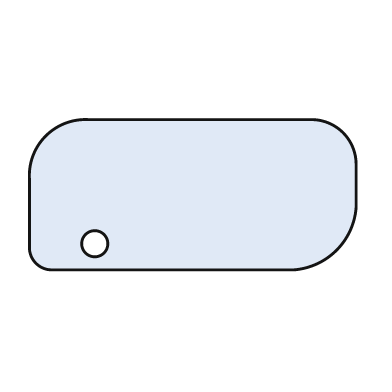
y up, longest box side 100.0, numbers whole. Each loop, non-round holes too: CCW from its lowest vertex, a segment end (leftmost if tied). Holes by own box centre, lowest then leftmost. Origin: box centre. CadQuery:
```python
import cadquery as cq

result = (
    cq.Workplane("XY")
    .moveTo(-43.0, -23.0)
    .lineTo(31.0, -23.0)
    .threePointArc((44.0, -17.0), (50.0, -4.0))
    .lineTo(50.0, 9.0)
    .threePointArc((46.0, 19.0), (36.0, 23.0))
    .lineTo(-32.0, 23.0)
    .threePointArc((-45.0, 18.0), (-50.0, 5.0))
    .lineTo(-50.0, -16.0)
    .threePointArc((-48.0, -21.0), (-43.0, -23.0))
    .close()
    .moveTo(-30.0, -15.0)
    .circle(4.0)
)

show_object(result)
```